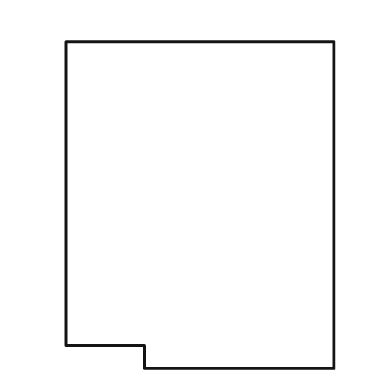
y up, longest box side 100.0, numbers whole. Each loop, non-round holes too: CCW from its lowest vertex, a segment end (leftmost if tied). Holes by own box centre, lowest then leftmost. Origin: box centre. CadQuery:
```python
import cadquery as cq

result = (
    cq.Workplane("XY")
    .moveTo(-17.0, -50.0)
    .lineTo(41.0, -50.0)
    .lineTo(41.0, 50.0)
    .lineTo(-41.0, 50.0)
    .lineTo(-41.0, -43.0)
    .lineTo(-17.0, -43.0)
    .close()
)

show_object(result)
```